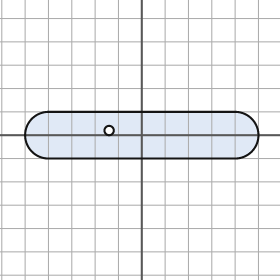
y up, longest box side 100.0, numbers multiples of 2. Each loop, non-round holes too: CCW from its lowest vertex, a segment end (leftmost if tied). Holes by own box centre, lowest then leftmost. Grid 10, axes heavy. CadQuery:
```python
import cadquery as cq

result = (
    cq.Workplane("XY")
    .moveTo(-40.0, -10.0)
    .lineTo(40.0, -10.0)
    .threePointArc((50.0, 0.0), (40.0, 10.0))
    .lineTo(-40.0, 10.0)
    .threePointArc((-50.0, 0.0), (-40.0, -10.0))
    .close()
    .moveTo(-14.0, 2.0)
    .circle(2.0)
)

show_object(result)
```